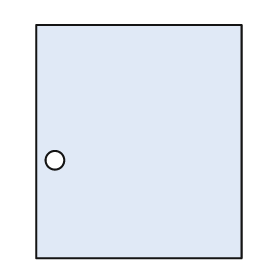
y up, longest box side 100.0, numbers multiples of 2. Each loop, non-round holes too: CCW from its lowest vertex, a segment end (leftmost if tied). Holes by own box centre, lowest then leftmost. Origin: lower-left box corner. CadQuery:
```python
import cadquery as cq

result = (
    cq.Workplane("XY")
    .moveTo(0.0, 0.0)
    .lineTo(88.0, 0.0)
    .lineTo(88.0, 100.0)
    .lineTo(0.0, 100.0)
    .close()
    .moveTo(8.0, 42.0)
    .circle(4.0)
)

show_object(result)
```